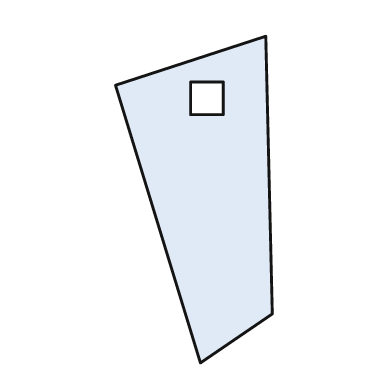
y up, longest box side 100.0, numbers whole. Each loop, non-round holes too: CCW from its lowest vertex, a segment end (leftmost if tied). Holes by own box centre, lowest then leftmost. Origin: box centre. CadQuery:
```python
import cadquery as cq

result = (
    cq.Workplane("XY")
    .moveTo(2.0, -50.0)
    .lineTo(24.0, -35.0)
    .lineTo(22.0, 50.0)
    .lineTo(-24.0, 35.0)
    .close()
    .moveTo(-1.0, 26.0)
    .lineTo(9.0, 26.0)
    .lineTo(9.0, 36.0)
    .lineTo(-1.0, 36.0)
    .close()
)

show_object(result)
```